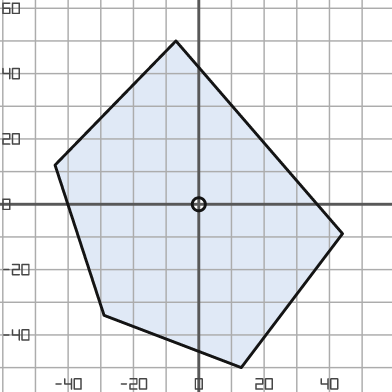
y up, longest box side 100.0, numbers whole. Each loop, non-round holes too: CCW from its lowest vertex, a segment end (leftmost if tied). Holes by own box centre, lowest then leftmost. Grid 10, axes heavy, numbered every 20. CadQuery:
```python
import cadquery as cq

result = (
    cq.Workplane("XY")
    .moveTo(13.0, -50.0)
    .lineTo(44.0, -9.0)
    .lineTo(-7.0, 50.0)
    .lineTo(-44.0, 12.0)
    .lineTo(-29.0, -34.0)
    .close()
    .moveTo(0.0, 0.0)
    .circle(2.0)
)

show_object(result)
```